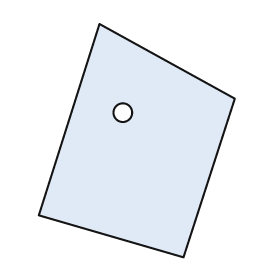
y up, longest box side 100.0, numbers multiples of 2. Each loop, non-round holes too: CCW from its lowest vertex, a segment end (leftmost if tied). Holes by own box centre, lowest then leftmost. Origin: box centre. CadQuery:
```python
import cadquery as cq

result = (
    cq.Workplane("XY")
    .moveTo(20.0, -50.0)
    .lineTo(42.0, 18.0)
    .lineTo(-16.0, 50.0)
    .lineTo(-42.0, -32.0)
    .close()
    .moveTo(-6.0, 12.0)
    .circle(4.0)
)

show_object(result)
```